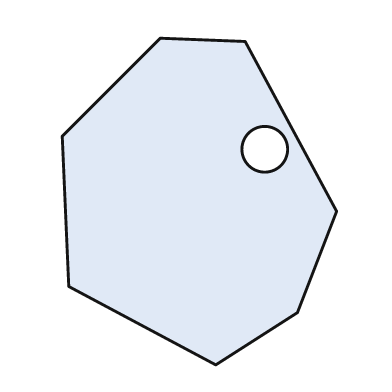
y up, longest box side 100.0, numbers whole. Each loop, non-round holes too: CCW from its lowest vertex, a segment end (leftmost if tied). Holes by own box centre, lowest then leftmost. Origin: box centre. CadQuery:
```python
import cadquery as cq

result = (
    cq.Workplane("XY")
    .moveTo(5.0, -50.0)
    .lineTo(30.0, -34.0)
    .lineTo(42.0, -3.0)
    .lineTo(14.0, 49.0)
    .lineTo(-12.0, 50.0)
    .lineTo(-42.0, 20.0)
    .lineTo(-40.0, -26.0)
    .close()
    .moveTo(20.0, 16.0)
    .circle(7.0)
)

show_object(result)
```